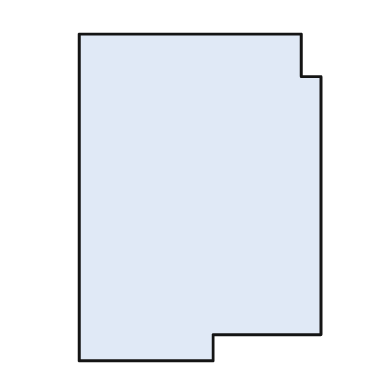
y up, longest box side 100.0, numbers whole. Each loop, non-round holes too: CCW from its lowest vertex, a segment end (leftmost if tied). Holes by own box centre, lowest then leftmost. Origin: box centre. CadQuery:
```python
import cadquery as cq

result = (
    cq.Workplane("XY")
    .moveTo(-37.0, -50.0)
    .lineTo(4.0, -50.0)
    .lineTo(4.0, -42.0)
    .lineTo(37.0, -42.0)
    .lineTo(37.0, 37.0)
    .lineTo(31.0, 37.0)
    .lineTo(31.0, 50.0)
    .lineTo(-37.0, 50.0)
    .close()
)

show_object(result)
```